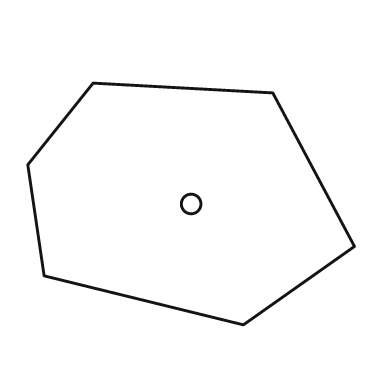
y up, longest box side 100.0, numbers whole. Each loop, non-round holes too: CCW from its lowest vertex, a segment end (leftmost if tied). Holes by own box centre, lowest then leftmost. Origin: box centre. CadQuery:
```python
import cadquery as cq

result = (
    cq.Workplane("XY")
    .moveTo(16.0, -37.0)
    .lineTo(50.0, -13.0)
    .lineTo(25.0, 34.0)
    .lineTo(-30.0, 37.0)
    .lineTo(-50.0, 12.0)
    .lineTo(-45.0, -22.0)
    .close()
    .moveTo(0.0, 0.0)
    .circle(3.0)
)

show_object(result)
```